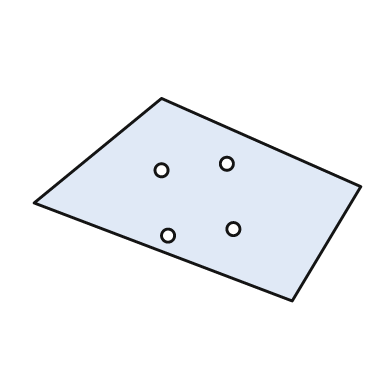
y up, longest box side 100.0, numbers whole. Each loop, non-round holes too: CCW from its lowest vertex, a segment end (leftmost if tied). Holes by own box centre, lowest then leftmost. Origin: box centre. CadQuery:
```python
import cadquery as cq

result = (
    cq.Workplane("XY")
    .moveTo(29.0, -31.0)
    .lineTo(50.0, 4.0)
    .lineTo(-11.0, 31.0)
    .lineTo(-50.0, -1.0)
    .close()
    .moveTo(-9.0, -11.0)
    .circle(2.0)
    .moveTo(11.0, -9.0)
    .circle(2.0)
    .moveTo(-11.0, 9.0)
    .circle(2.0)
    .moveTo(9.0, 11.0)
    .circle(2.0)
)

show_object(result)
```